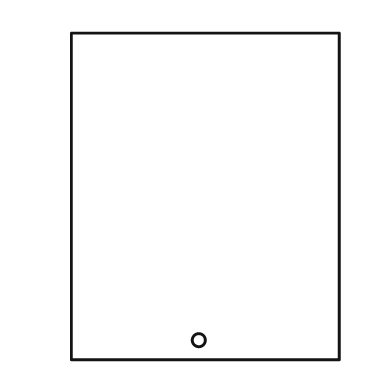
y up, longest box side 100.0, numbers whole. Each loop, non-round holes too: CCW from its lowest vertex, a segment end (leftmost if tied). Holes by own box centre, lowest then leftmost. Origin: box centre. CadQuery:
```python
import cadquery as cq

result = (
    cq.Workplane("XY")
    .moveTo(-41.0, -50.0)
    .lineTo(41.0, -50.0)
    .lineTo(41.0, 50.0)
    .lineTo(-41.0, 50.0)
    .close()
    .moveTo(-2.0, -44.0)
    .circle(2.0)
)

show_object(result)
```